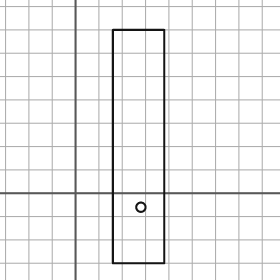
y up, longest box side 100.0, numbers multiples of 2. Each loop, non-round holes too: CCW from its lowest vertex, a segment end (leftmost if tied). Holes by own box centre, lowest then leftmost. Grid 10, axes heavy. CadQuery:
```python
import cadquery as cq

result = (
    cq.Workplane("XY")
    .moveTo(16.0, -30.0)
    .lineTo(38.0, -30.0)
    .lineTo(38.0, 70.0)
    .lineTo(16.0, 70.0)
    .close()
    .moveTo(28.0, -6.0)
    .circle(2.0)
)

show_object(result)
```